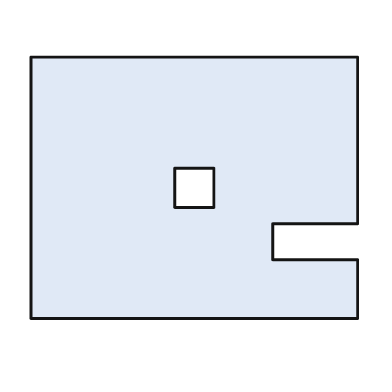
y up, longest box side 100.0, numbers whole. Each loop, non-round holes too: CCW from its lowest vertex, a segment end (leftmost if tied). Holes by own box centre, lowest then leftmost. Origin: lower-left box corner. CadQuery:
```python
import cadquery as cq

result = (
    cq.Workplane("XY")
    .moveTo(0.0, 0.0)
    .lineTo(100.0, 0.0)
    .lineTo(100.0, 18.0)
    .lineTo(74.0, 18.0)
    .lineTo(74.0, 29.0)
    .lineTo(100.0, 29.0)
    .lineTo(100.0, 80.0)
    .lineTo(0.0, 80.0)
    .close()
    .moveTo(44.0, 34.0)
    .lineTo(56.0, 34.0)
    .lineTo(56.0, 46.0)
    .lineTo(44.0, 46.0)
    .close()
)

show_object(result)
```